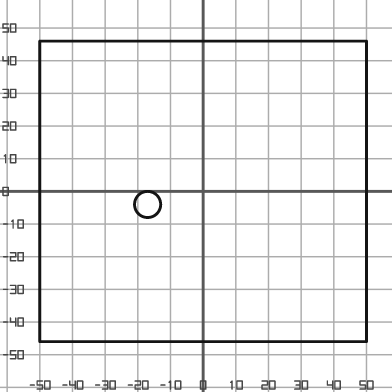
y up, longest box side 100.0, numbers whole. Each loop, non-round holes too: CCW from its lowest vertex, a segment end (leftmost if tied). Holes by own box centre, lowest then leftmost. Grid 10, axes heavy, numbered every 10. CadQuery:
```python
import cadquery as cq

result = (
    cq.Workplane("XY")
    .moveTo(-50.0, -46.0)
    .lineTo(50.0, -46.0)
    .lineTo(50.0, 46.0)
    .lineTo(-50.0, 46.0)
    .close()
    .moveTo(-17.0, -4.0)
    .circle(4.0)
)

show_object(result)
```